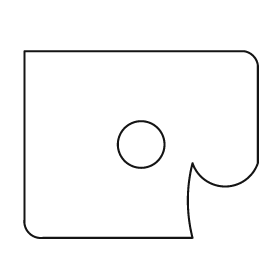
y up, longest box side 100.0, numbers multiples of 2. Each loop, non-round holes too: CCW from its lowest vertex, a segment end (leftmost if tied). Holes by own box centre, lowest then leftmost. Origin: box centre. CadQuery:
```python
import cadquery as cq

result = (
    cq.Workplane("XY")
    .moveTo(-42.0, -40.0)
    .lineTo(22.0, -40.0)
    .threePointArc((20.0, -24.0), (22.0, -8.0))
    .threePointArc((36.0, -18.0), (50.0, -8.0))
    .lineTo(50.0, 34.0)
    .threePointArc((48.0, 38.0), (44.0, 40.0))
    .lineTo(-50.0, 40.0)
    .lineTo(-50.0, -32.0)
    .threePointArc((-48.0, -38.0), (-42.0, -40.0))
    .close()
    .moveTo(0.0, 0.0)
    .circle(10.0)
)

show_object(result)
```